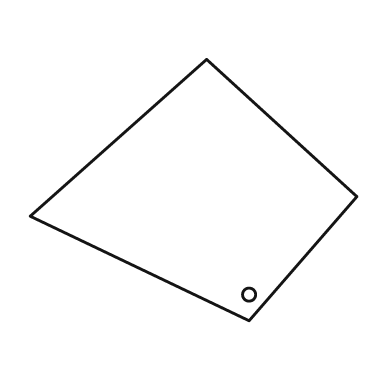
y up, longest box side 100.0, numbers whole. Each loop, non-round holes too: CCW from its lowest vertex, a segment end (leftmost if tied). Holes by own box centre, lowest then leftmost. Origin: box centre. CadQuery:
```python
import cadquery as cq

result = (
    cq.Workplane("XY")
    .moveTo(17.0, -40.0)
    .lineTo(50.0, -2.0)
    .lineTo(4.0, 40.0)
    .lineTo(-50.0, -8.0)
    .close()
    .moveTo(17.0, -32.0)
    .circle(2.0)
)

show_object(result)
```